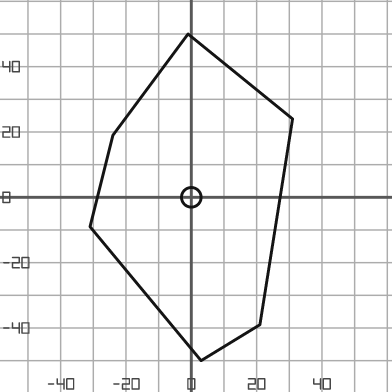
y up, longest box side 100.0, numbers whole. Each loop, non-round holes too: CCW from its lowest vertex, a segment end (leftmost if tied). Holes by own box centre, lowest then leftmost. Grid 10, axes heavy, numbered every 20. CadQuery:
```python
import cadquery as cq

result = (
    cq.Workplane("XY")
    .moveTo(3.0, -50.0)
    .lineTo(21.0, -39.0)
    .lineTo(31.0, 24.0)
    .lineTo(-1.0, 50.0)
    .lineTo(-24.0, 19.0)
    .lineTo(-31.0, -9.0)
    .close()
    .moveTo(0.0, 0.0)
    .circle(3.0)
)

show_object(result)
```